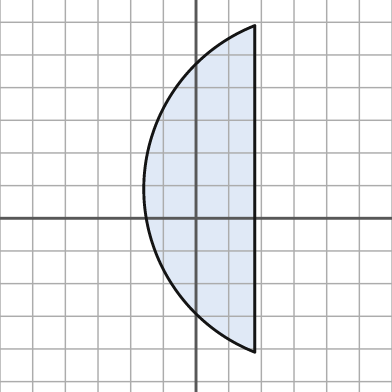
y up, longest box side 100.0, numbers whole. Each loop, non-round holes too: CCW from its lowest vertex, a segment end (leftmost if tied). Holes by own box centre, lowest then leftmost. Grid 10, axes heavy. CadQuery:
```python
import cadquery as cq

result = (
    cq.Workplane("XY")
    .moveTo(18.0, -41.0)
    .lineTo(18.0, 59.0)
    .threePointArc((-16.0, 9.0), (18.0, -41.0))
    .close()
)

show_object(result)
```